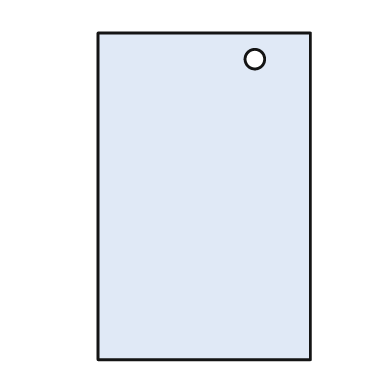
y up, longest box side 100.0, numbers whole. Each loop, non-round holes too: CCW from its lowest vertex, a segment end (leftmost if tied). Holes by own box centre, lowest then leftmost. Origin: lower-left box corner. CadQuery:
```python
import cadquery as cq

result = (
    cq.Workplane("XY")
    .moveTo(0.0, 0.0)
    .lineTo(65.0, 0.0)
    .lineTo(65.0, 100.0)
    .lineTo(0.0, 100.0)
    .close()
    .moveTo(48.0, 92.0)
    .circle(3.0)
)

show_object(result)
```